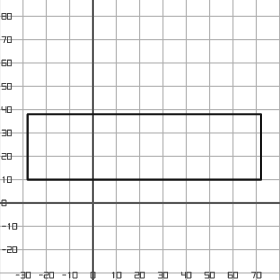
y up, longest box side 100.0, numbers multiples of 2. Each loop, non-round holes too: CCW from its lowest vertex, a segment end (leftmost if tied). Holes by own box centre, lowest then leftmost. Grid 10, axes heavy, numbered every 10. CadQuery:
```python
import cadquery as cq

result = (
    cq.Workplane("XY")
    .moveTo(-28.0, 10.0)
    .lineTo(72.0, 10.0)
    .lineTo(72.0, 38.0)
    .lineTo(-28.0, 38.0)
    .close()
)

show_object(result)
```